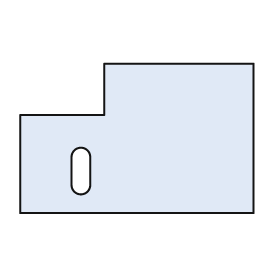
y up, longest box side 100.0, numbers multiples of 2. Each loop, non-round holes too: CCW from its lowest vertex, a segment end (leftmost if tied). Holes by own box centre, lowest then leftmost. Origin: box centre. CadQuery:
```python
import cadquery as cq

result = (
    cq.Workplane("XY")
    .moveTo(-50.0, -32.0)
    .lineTo(50.0, -32.0)
    .lineTo(50.0, 32.0)
    .lineTo(-14.0, 32.0)
    .lineTo(-14.0, 10.0)
    .lineTo(-50.0, 10.0)
    .close()
    .moveTo(-28.0, -20.0)
    .threePointArc((-24.0, -24.0), (-20.0, -20.0))
    .lineTo(-20.0, -8.0)
    .threePointArc((-24.0, -4.0), (-28.0, -8.0))
    .close()
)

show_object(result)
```